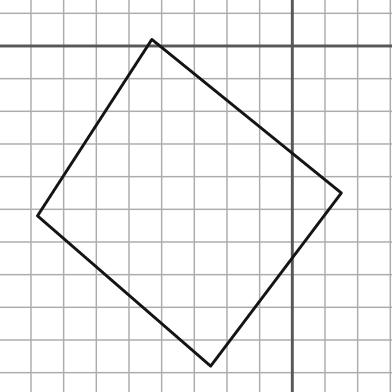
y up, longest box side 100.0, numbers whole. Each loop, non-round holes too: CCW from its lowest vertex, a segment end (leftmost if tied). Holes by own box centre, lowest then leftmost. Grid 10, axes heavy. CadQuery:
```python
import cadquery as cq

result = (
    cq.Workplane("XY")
    .moveTo(-25.0, -98.0)
    .lineTo(15.0, -45.0)
    .lineTo(-43.0, 2.0)
    .lineTo(-78.0, -52.0)
    .close()
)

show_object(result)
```